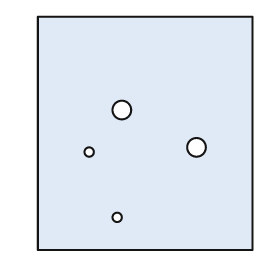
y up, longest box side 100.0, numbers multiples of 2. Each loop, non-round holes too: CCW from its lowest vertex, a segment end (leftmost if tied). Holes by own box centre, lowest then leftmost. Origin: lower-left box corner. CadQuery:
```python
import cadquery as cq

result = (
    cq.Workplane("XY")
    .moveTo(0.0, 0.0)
    .lineTo(92.0, 0.0)
    .lineTo(92.0, 100.0)
    .lineTo(0.0, 100.0)
    .close()
    .moveTo(34.0, 14.0)
    .circle(2.0)
    .moveTo(22.0, 42.0)
    .circle(2.0)
    .moveTo(68.0, 44.0)
    .circle(4.0)
    .moveTo(36.0, 60.0)
    .circle(4.0)
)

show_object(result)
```